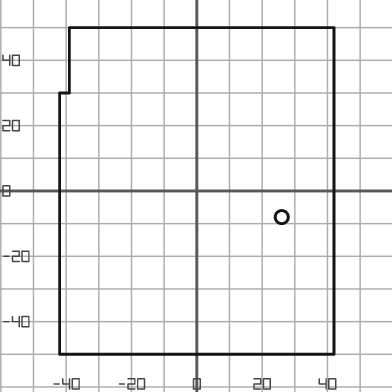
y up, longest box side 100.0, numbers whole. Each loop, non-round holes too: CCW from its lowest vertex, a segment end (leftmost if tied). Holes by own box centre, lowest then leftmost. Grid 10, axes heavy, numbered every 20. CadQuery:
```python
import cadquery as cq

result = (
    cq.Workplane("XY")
    .moveTo(-42.0, -50.0)
    .lineTo(42.0, -50.0)
    .lineTo(42.0, 50.0)
    .lineTo(-39.0, 50.0)
    .lineTo(-39.0, 30.0)
    .lineTo(-42.0, 30.0)
    .close()
    .moveTo(26.0, -8.0)
    .circle(2.0)
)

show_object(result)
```